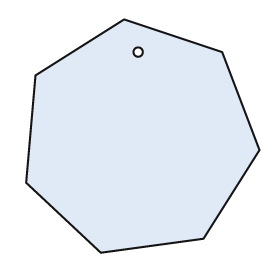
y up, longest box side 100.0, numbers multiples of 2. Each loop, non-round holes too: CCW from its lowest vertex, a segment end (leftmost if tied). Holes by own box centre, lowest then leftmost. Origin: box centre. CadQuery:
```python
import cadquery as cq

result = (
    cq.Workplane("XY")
    .moveTo(-18.0, -50.0)
    .lineTo(26.0, -44.0)
    .lineTo(50.0, -6.0)
    .lineTo(34.0, 36.0)
    .lineTo(-8.0, 50.0)
    .lineTo(-46.0, 26.0)
    .lineTo(-50.0, -20.0)
    .close()
    .moveTo(-2.0, 36.0)
    .circle(2.0)
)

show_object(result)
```